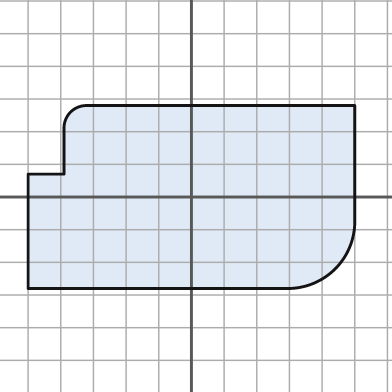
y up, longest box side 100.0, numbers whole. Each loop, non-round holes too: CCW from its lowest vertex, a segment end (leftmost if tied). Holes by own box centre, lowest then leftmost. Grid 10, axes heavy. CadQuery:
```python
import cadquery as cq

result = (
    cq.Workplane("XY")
    .moveTo(-50.0, -28.0)
    .lineTo(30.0, -28.0)
    .threePointArc((44.0, -22.0), (50.0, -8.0))
    .lineTo(50.0, 28.0)
    .lineTo(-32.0, 28.0)
    .threePointArc((-37.0, 26.0), (-39.0, 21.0))
    .lineTo(-39.0, 7.0)
    .lineTo(-50.0, 7.0)
    .close()
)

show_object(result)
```